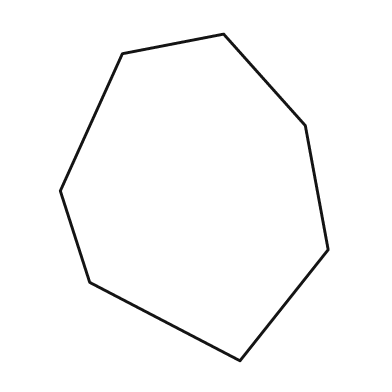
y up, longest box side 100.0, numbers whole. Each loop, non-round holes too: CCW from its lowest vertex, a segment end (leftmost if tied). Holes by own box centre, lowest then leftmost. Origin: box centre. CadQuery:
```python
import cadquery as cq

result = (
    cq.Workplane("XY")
    .moveTo(14.0, -50.0)
    .lineTo(41.0, -16.0)
    .lineTo(34.0, 22.0)
    .lineTo(9.0, 50.0)
    .lineTo(-22.0, 44.0)
    .lineTo(-41.0, 2.0)
    .lineTo(-32.0, -26.0)
    .close()
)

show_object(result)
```